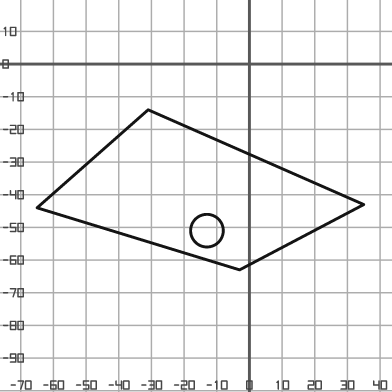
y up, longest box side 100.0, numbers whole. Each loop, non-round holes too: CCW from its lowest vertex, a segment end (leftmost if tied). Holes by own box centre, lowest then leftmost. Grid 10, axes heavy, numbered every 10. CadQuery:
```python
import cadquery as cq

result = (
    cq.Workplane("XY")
    .moveTo(-3.0, -63.0)
    .lineTo(35.0, -43.0)
    .lineTo(-31.0, -14.0)
    .lineTo(-65.0, -44.0)
    .close()
    .moveTo(-13.0, -51.0)
    .circle(5.0)
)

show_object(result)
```